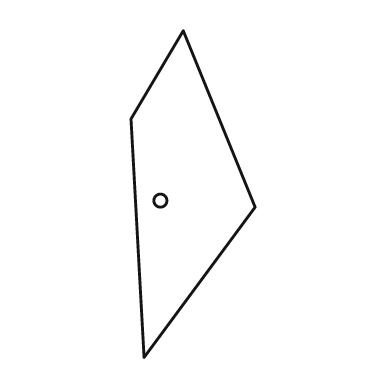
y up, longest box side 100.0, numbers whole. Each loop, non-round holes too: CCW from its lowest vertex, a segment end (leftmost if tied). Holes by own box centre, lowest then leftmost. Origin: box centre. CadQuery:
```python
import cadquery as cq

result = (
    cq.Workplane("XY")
    .moveTo(-15.0, -50.0)
    .lineTo(19.0, -4.0)
    .lineTo(-3.0, 50.0)
    .lineTo(-19.0, 23.0)
    .close()
    .moveTo(-10.0, -2.0)
    .circle(2.0)
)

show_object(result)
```